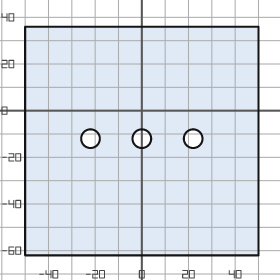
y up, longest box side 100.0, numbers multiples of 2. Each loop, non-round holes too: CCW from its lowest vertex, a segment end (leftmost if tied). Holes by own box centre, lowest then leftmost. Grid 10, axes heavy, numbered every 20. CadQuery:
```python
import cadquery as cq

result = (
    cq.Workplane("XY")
    .moveTo(-50.0, -62.0)
    .lineTo(50.0, -62.0)
    .lineTo(50.0, 36.0)
    .lineTo(-50.0, 36.0)
    .close()
    .moveTo(-22.0, -12.0)
    .circle(4.0)
    .moveTo(0.0, -12.0)
    .circle(4.0)
    .moveTo(22.0, -12.0)
    .circle(4.0)
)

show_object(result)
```